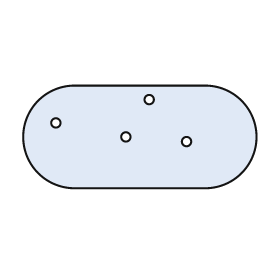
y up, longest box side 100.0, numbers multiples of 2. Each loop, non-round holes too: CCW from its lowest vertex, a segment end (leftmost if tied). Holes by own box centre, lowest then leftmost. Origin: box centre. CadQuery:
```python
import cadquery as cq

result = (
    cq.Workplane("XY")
    .moveTo(-28.0, -22.0)
    .lineTo(28.0, -22.0)
    .threePointArc((50.0, 0.0), (28.0, 22.0))
    .lineTo(-28.0, 22.0)
    .threePointArc((-50.0, 0.0), (-28.0, -22.0))
    .close()
    .moveTo(20.0, -2.0)
    .circle(2.0)
    .moveTo(-6.0, 0.0)
    .circle(2.0)
    .moveTo(-36.0, 6.0)
    .circle(2.0)
    .moveTo(4.0, 16.0)
    .circle(2.0)
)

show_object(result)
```